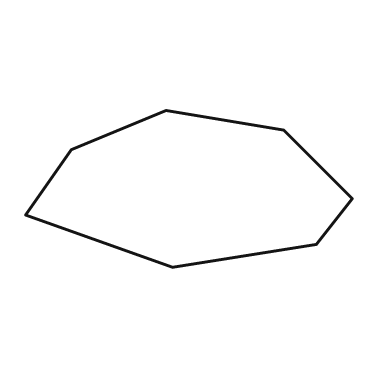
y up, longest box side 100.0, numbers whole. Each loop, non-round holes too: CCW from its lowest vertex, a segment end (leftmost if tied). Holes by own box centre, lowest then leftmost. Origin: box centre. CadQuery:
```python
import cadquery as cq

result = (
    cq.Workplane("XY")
    .moveTo(-5.0, -24.0)
    .lineTo(39.0, -17.0)
    .lineTo(50.0, -3.0)
    .lineTo(29.0, 18.0)
    .lineTo(-7.0, 24.0)
    .lineTo(-36.0, 12.0)
    .lineTo(-50.0, -8.0)
    .close()
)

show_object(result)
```